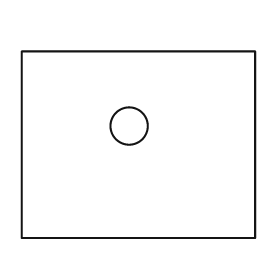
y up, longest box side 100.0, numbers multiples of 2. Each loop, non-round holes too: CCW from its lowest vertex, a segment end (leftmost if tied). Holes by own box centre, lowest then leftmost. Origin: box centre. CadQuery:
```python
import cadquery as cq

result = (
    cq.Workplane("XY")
    .moveTo(-50.0, -40.0)
    .lineTo(50.0, -40.0)
    .lineTo(50.0, 40.0)
    .lineTo(-50.0, 40.0)
    .close()
    .moveTo(-4.0, 8.0)
    .circle(8.0)
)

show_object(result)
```